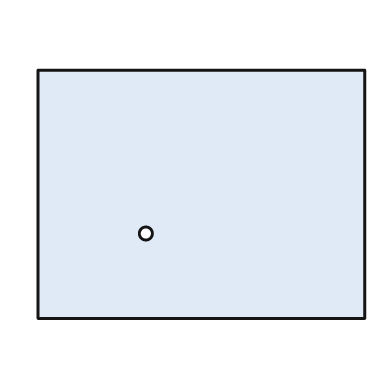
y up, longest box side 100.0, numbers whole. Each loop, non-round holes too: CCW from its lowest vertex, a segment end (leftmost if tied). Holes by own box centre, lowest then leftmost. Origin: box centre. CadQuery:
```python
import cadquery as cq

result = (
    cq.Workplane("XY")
    .moveTo(-50.0, -38.0)
    .lineTo(50.0, -38.0)
    .lineTo(50.0, 38.0)
    .lineTo(-50.0, 38.0)
    .close()
    .moveTo(-17.0, -12.0)
    .circle(2.0)
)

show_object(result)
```